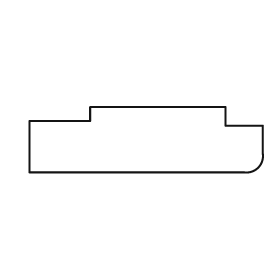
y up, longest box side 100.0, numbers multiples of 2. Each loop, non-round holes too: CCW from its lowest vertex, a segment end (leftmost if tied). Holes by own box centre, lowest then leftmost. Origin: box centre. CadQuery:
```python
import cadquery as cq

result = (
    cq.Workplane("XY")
    .moveTo(-50.0, -14.0)
    .lineTo(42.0, -14.0)
    .threePointArc((48.0, -12.0), (50.0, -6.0))
    .lineTo(50.0, 6.0)
    .lineTo(34.0, 6.0)
    .lineTo(34.0, 14.0)
    .lineTo(-24.0, 14.0)
    .lineTo(-24.0, 8.0)
    .lineTo(-50.0, 8.0)
    .close()
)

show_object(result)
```